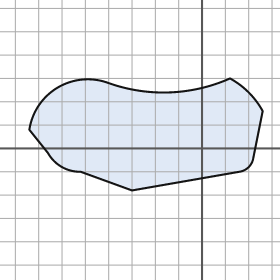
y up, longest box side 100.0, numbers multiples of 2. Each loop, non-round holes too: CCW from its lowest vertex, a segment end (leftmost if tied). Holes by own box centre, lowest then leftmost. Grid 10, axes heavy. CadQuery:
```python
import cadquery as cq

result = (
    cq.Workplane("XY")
    .moveTo(-30.0, -18.0)
    .lineTo(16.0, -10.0)
    .threePointArc((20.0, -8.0), (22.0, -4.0))
    .lineTo(26.0, 16.0)
    .threePointArc((20.0, 24.0), (12.0, 30.0))
    .threePointArc((-14.0, 24.0), (-40.0, 28.0))
    .threePointArc((-62.0, 26.0), (-74.0, 8.0))
    .lineTo(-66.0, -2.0)
    .threePointArc((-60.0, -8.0), (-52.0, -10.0))
    .close()
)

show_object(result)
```